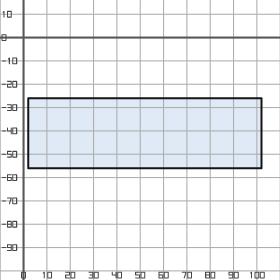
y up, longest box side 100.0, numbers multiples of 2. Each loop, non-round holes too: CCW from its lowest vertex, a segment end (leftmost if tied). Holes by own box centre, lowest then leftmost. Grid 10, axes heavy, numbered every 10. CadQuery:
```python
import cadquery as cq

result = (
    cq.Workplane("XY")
    .moveTo(2.0, -56.0)
    .lineTo(102.0, -56.0)
    .lineTo(102.0, -26.0)
    .lineTo(2.0, -26.0)
    .close()
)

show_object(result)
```